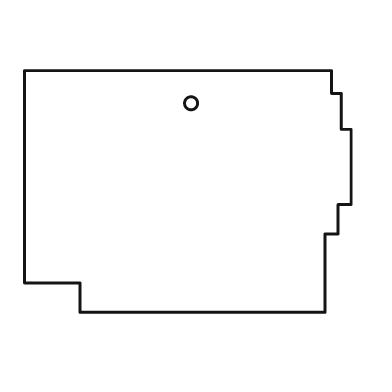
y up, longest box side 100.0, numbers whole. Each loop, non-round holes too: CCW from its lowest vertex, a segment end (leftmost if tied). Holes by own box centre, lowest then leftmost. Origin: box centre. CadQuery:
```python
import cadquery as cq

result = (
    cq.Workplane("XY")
    .moveTo(-33.0, -37.0)
    .lineTo(42.0, -37.0)
    .lineTo(42.0, -13.0)
    .lineTo(46.0, -13.0)
    .lineTo(46.0, -4.0)
    .lineTo(50.0, -4.0)
    .lineTo(50.0, 19.0)
    .lineTo(47.0, 19.0)
    .lineTo(47.0, 30.0)
    .lineTo(44.0, 30.0)
    .lineTo(44.0, 37.0)
    .lineTo(-50.0, 37.0)
    .lineTo(-50.0, -28.0)
    .lineTo(-33.0, -28.0)
    .close()
    .moveTo(1.0, 27.0)
    .circle(2.0)
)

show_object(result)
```